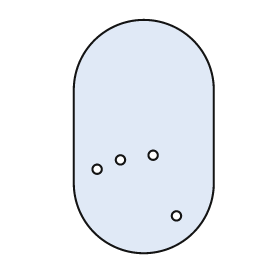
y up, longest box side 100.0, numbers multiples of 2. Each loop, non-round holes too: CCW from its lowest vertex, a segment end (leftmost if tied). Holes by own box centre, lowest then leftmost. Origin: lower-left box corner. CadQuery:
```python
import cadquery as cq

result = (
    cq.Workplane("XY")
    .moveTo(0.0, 30.0)
    .threePointArc((30.0, 0.0), (60.0, 30.0))
    .lineTo(60.0, 70.0)
    .threePointArc((30.0, 100.0), (0.0, 70.0))
    .close()
    .moveTo(44.0, 16.0)
    .circle(2.0)
    .moveTo(10.0, 36.0)
    .circle(2.0)
    .moveTo(20.0, 40.0)
    .circle(2.0)
    .moveTo(34.0, 42.0)
    .circle(2.0)
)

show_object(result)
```